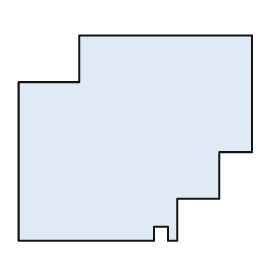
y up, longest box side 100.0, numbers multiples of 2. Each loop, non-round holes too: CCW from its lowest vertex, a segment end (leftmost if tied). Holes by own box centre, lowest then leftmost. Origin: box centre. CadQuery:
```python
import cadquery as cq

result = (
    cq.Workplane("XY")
    .moveTo(-50.0, -44.0)
    .lineTo(8.0, -44.0)
    .lineTo(8.0, -38.0)
    .lineTo(14.0, -38.0)
    .lineTo(14.0, -44.0)
    .lineTo(18.0, -44.0)
    .lineTo(18.0, -26.0)
    .lineTo(36.0, -26.0)
    .lineTo(36.0, -6.0)
    .lineTo(50.0, -6.0)
    .lineTo(50.0, 44.0)
    .lineTo(-24.0, 44.0)
    .lineTo(-24.0, 24.0)
    .lineTo(-50.0, 24.0)
    .close()
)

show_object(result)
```